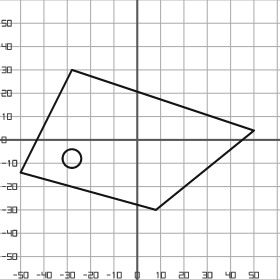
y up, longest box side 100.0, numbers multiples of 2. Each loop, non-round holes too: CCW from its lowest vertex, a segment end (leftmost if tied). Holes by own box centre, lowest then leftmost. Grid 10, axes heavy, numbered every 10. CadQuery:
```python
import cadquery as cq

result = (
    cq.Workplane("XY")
    .moveTo(8.0, -30.0)
    .lineTo(50.0, 4.0)
    .lineTo(-28.0, 30.0)
    .lineTo(-50.0, -14.0)
    .close()
    .moveTo(-28.0, -8.0)
    .circle(4.0)
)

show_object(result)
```